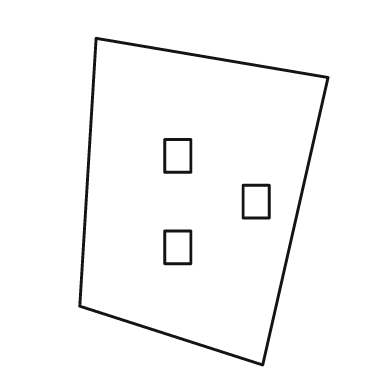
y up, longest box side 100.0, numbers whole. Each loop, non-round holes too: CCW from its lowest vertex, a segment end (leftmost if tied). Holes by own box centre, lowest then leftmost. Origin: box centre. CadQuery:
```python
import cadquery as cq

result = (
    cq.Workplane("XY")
    .moveTo(18.0, -50.0)
    .lineTo(38.0, 38.0)
    .lineTo(-33.0, 50.0)
    .lineTo(-38.0, -32.0)
    .close()
    .moveTo(-12.0, -19.0)
    .lineTo(-4.0, -19.0)
    .lineTo(-4.0, -9.0)
    .lineTo(-12.0, -9.0)
    .close()
    .moveTo(12.0, -5.0)
    .lineTo(20.0, -5.0)
    .lineTo(20.0, 5.0)
    .lineTo(12.0, 5.0)
    .close()
    .moveTo(-12.0, 9.0)
    .lineTo(-4.0, 9.0)
    .lineTo(-4.0, 19.0)
    .lineTo(-12.0, 19.0)
    .close()
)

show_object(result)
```